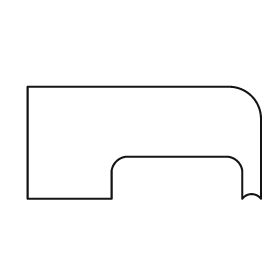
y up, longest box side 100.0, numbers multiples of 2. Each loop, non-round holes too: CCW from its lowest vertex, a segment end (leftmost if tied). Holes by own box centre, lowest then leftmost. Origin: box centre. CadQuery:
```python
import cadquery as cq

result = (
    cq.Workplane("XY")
    .moveTo(-50.0, -24.0)
    .lineTo(-14.0, -24.0)
    .lineTo(-14.0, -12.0)
    .threePointArc((-12.0, -8.0), (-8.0, -6.0))
    .lineTo(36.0, -6.0)
    .threePointArc((40.0, -8.0), (42.0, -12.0))
    .lineTo(42.0, -24.0)
    .threePointArc((46.0, -22.0), (50.0, -24.0))
    .lineTo(50.0, 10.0)
    .threePointArc((46.0, 20.0), (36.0, 24.0))
    .lineTo(-50.0, 24.0)
    .close()
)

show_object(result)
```